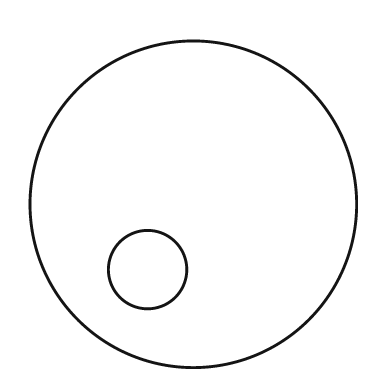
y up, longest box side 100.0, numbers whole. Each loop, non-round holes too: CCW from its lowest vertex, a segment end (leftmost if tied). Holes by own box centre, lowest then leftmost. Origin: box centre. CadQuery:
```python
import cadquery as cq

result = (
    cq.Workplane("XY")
    .moveTo(0.0, 0.0)
    .circle(50.0)
    .moveTo(-14.0, -20.0)
    .circle(12.0)
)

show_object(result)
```